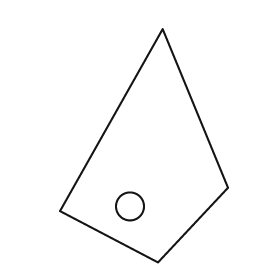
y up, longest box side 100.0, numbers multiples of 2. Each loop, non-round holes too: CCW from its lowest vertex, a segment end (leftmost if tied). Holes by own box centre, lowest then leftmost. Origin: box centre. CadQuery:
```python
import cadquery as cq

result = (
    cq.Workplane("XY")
    .moveTo(6.0, -50.0)
    .lineTo(36.0, -18.0)
    .lineTo(8.0, 50.0)
    .lineTo(-36.0, -28.0)
    .close()
    .moveTo(-6.0, -26.0)
    .circle(6.0)
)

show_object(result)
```